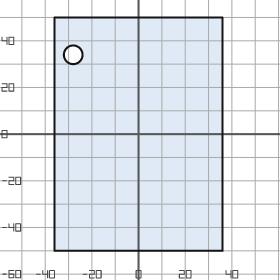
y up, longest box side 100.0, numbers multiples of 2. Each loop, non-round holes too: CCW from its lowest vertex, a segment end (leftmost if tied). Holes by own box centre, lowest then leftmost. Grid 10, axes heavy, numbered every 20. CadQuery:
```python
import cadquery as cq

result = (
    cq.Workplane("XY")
    .moveTo(-36.0, -50.0)
    .lineTo(36.0, -50.0)
    .lineTo(36.0, 50.0)
    .lineTo(-36.0, 50.0)
    .close()
    .moveTo(-28.0, 34.0)
    .circle(4.0)
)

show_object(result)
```